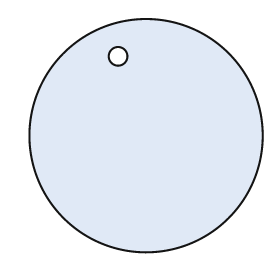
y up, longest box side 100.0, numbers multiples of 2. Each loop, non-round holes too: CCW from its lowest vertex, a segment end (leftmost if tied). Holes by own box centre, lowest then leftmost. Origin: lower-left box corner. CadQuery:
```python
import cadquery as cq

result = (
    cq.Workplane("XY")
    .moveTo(50.0, 50.0)
    .circle(50.0)
    .moveTo(38.0, 84.0)
    .circle(4.0)
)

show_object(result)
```